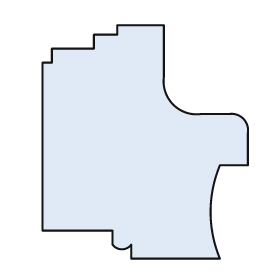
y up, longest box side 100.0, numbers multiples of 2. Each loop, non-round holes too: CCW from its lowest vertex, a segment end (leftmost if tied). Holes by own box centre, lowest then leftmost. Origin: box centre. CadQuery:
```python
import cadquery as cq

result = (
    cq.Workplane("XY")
    .moveTo(-6.0, -50.0)
    .lineTo(32.0, -50.0)
    .threePointArc((28.0, -30.0), (32.0, -10.0))
    .lineTo(44.0, -10.0)
    .lineTo(44.0, 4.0)
    .threePointArc((42.0, 10.0), (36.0, 12.0))
    .lineTo(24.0, 12.0)
    .threePointArc((12.0, 16.0), (8.0, 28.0))
    .lineTo(8.0, 50.0)
    .lineTo(-12.0, 50.0)
    .lineTo(-12.0, 46.0)
    .lineTo(-22.0, 46.0)
    .lineTo(-22.0, 40.0)
    .lineTo(-40.0, 40.0)
    .lineTo(-40.0, 34.0)
    .lineTo(-44.0, 34.0)
    .lineTo(-44.0, -38.0)
    .lineTo(-14.0, -38.0)
    .lineTo(-14.0, -44.0)
    .threePointArc((-10.0, -46.0), (-6.0, -44.0))
    .close()
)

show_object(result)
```